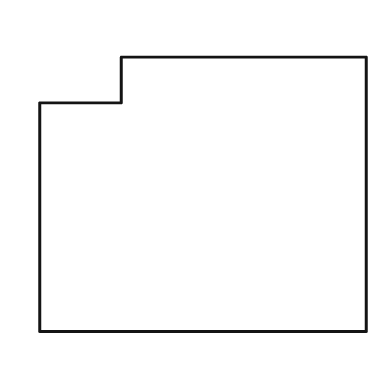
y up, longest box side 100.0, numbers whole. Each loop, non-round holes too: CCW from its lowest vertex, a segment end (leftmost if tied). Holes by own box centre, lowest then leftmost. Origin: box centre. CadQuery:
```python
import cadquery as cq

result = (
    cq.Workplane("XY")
    .moveTo(-50.0, -42.0)
    .lineTo(50.0, -42.0)
    .lineTo(50.0, 42.0)
    .lineTo(-25.0, 42.0)
    .lineTo(-25.0, 28.0)
    .lineTo(-50.0, 28.0)
    .close()
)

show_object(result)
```